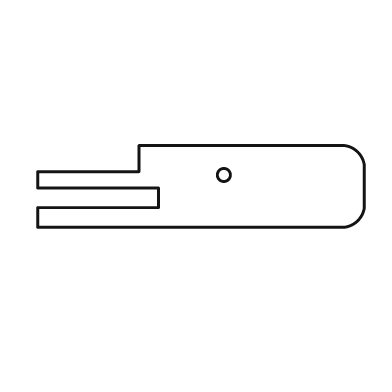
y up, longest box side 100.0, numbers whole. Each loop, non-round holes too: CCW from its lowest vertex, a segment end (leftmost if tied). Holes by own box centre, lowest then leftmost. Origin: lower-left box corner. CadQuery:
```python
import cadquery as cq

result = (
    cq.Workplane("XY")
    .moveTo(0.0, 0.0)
    .lineTo(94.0, 0.0)
    .threePointArc((98.0, 2.0), (100.0, 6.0))
    .lineTo(100.0, 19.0)
    .threePointArc((98.0, 23.0), (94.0, 25.0))
    .lineTo(31.0, 25.0)
    .lineTo(31.0, 17.0)
    .lineTo(0.0, 17.0)
    .lineTo(0.0, 12.0)
    .lineTo(37.0, 12.0)
    .lineTo(37.0, 6.0)
    .lineTo(0.0, 6.0)
    .close()
    .moveTo(57.0, 16.0)
    .circle(2.0)
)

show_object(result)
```